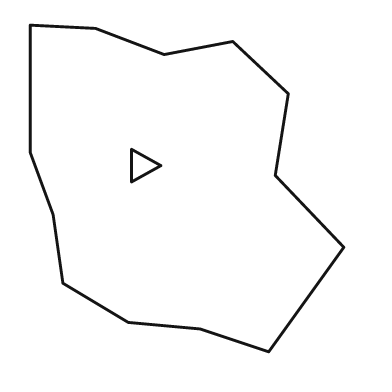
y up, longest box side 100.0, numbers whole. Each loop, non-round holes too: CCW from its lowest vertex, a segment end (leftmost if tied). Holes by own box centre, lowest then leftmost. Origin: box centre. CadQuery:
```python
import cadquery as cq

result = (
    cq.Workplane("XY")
    .moveTo(25.0, -50.0)
    .lineTo(48.0, -18.0)
    .lineTo(27.0, 4.0)
    .lineTo(31.0, 29.0)
    .lineTo(14.0, 45.0)
    .lineTo(-7.0, 41.0)
    .lineTo(-28.0, 49.0)
    .lineTo(-48.0, 50.0)
    .lineTo(-48.0, 11.0)
    .lineTo(-41.0, -8.0)
    .lineTo(-38.0, -29.0)
    .lineTo(-18.0, -41.0)
    .lineTo(4.0, -43.0)
    .close()
    .moveTo(-17.0, 2.0)
    .lineTo(-8.0, 7.0)
    .lineTo(-17.0, 12.0)
    .close()
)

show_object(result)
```